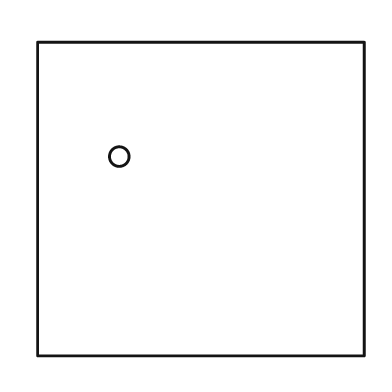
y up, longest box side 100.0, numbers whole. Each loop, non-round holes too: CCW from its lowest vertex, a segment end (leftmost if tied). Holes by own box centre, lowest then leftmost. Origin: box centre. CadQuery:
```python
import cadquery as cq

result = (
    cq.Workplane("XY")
    .moveTo(-50.0, -48.0)
    .lineTo(50.0, -48.0)
    .lineTo(50.0, 48.0)
    .lineTo(-50.0, 48.0)
    .close()
    .moveTo(-25.0, 13.0)
    .circle(3.0)
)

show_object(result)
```